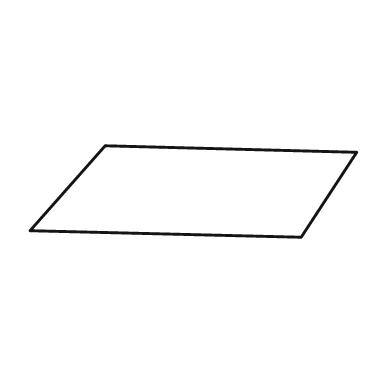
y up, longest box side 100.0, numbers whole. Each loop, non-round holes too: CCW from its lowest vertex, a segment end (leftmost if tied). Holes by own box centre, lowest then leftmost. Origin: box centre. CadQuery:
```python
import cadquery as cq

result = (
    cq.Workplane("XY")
    .moveTo(33.0, -14.0)
    .lineTo(50.0, 12.0)
    .lineTo(-27.0, 14.0)
    .lineTo(-50.0, -12.0)
    .close()
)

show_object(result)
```